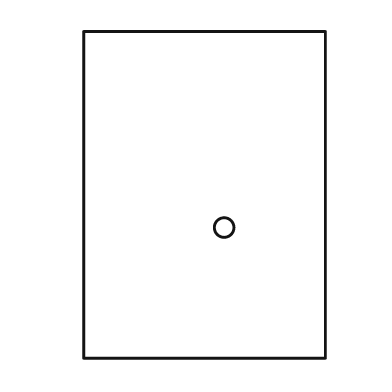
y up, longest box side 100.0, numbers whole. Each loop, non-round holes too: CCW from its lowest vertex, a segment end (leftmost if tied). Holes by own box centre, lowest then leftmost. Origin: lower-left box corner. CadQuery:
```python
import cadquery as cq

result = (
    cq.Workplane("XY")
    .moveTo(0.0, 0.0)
    .lineTo(74.0, 0.0)
    .lineTo(74.0, 100.0)
    .lineTo(0.0, 100.0)
    .close()
    .moveTo(43.0, 40.0)
    .circle(3.0)
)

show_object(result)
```